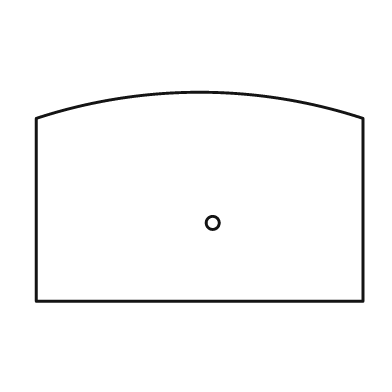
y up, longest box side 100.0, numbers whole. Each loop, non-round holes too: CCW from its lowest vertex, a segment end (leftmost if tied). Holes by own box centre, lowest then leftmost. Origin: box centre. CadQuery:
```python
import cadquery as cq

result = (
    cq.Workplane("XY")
    .moveTo(-50.0, -32.0)
    .lineTo(50.0, -32.0)
    .lineTo(50.0, 24.0)
    .threePointArc((0.0, 32.0), (-50.0, 24.0))
    .close()
    .moveTo(4.0, -8.0)
    .circle(2.0)
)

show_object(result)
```